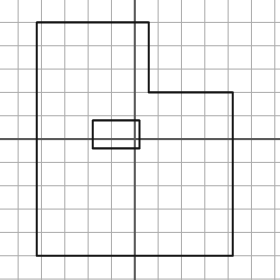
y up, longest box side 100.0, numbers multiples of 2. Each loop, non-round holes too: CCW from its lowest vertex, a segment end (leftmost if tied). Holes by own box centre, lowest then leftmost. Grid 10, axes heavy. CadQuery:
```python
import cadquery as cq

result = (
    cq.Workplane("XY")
    .moveTo(-42.0, -50.0)
    .lineTo(42.0, -50.0)
    .lineTo(42.0, 20.0)
    .lineTo(6.0, 20.0)
    .lineTo(6.0, 50.0)
    .lineTo(-42.0, 50.0)
    .close()
    .moveTo(-18.0, -4.0)
    .lineTo(2.0, -4.0)
    .lineTo(2.0, 8.0)
    .lineTo(-18.0, 8.0)
    .close()
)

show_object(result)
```